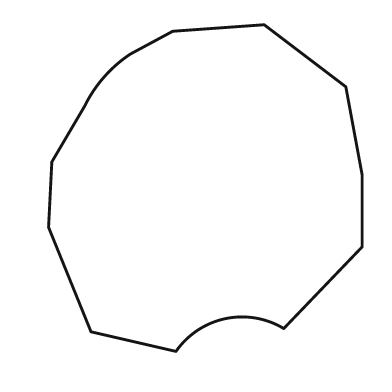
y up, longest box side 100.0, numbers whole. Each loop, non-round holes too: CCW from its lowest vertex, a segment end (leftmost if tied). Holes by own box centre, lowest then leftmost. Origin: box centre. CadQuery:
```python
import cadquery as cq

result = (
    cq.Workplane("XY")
    .moveTo(-9.0, -50.0)
    .threePointArc((6.0, -40.0), (24.0, -43.0))
    .lineTo(48.0, -18.0)
    .lineTo(48.0, 4.0)
    .lineTo(43.0, 31.0)
    .lineTo(18.0, 50.0)
    .lineTo(-10.0, 48.0)
    .lineTo(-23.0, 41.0)
    .threePointArc((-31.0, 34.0), (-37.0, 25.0))
    .lineTo(-47.0, 8.0)
    .lineTo(-48.0, -12.0)
    .lineTo(-35.0, -44.0)
    .close()
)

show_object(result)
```